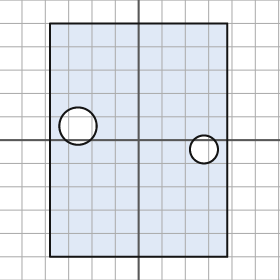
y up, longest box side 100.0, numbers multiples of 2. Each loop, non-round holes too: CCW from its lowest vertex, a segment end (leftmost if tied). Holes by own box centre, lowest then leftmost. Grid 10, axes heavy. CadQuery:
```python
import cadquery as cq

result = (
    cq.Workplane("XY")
    .moveTo(-38.0, -50.0)
    .lineTo(38.0, -50.0)
    .lineTo(38.0, 50.0)
    .lineTo(-38.0, 50.0)
    .close()
    .moveTo(28.0, -4.0)
    .circle(6.0)
    .moveTo(-26.0, 6.0)
    .circle(8.0)
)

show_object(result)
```